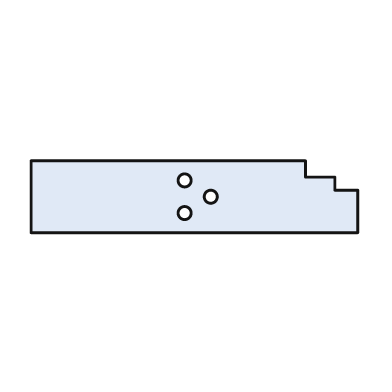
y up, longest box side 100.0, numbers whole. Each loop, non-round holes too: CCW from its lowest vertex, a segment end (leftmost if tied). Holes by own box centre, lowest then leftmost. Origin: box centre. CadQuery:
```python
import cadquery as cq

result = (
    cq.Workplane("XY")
    .moveTo(-50.0, -11.0)
    .lineTo(50.0, -11.0)
    .lineTo(50.0, 2.0)
    .lineTo(43.0, 2.0)
    .lineTo(43.0, 6.0)
    .lineTo(34.0, 6.0)
    .lineTo(34.0, 11.0)
    .lineTo(-50.0, 11.0)
    .close()
    .moveTo(-3.0, -5.0)
    .circle(2.0)
    .moveTo(5.0, 0.0)
    .circle(2.0)
    .moveTo(-3.0, 5.0)
    .circle(2.0)
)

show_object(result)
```